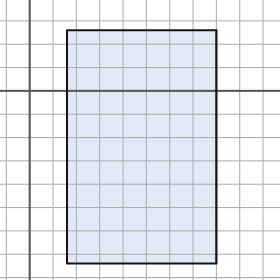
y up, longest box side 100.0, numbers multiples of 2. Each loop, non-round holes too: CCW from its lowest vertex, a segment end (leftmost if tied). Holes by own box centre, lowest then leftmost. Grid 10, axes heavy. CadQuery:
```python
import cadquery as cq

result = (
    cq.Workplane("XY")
    .moveTo(16.0, -74.0)
    .lineTo(80.0, -74.0)
    .lineTo(80.0, 26.0)
    .lineTo(16.0, 26.0)
    .close()
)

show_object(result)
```